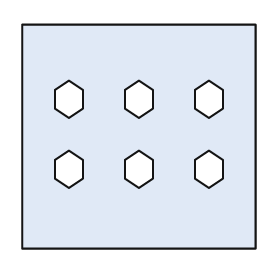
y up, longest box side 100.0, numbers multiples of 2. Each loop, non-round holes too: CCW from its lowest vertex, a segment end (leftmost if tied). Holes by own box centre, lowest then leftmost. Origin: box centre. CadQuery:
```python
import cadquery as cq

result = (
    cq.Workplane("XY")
    .moveTo(-50.0, -48.0)
    .lineTo(50.0, -48.0)
    .lineTo(50.0, 48.0)
    .lineTo(-50.0, 48.0)
    .close()
    .moveTo(-30.0, -22.0)
    .lineTo(-24.0, -18.0)
    .lineTo(-24.0, -10.0)
    .lineTo(-30.0, -6.0)
    .lineTo(-36.0, -10.0)
    .lineTo(-36.0, -18.0)
    .close()
    .moveTo(0.0, -22.0)
    .lineTo(6.0, -18.0)
    .lineTo(6.0, -10.0)
    .lineTo(0.0, -6.0)
    .lineTo(-6.0, -10.0)
    .lineTo(-6.0, -18.0)
    .close()
    .moveTo(30.0, -22.0)
    .lineTo(36.0, -18.0)
    .lineTo(36.0, -10.0)
    .lineTo(30.0, -6.0)
    .lineTo(24.0, -10.0)
    .lineTo(24.0, -18.0)
    .close()
    .moveTo(-30.0, 8.0)
    .lineTo(-24.0, 12.0)
    .lineTo(-24.0, 20.0)
    .lineTo(-30.0, 24.0)
    .lineTo(-36.0, 20.0)
    .lineTo(-36.0, 12.0)
    .close()
    .moveTo(0.0, 8.0)
    .lineTo(6.0, 12.0)
    .lineTo(6.0, 20.0)
    .lineTo(0.0, 24.0)
    .lineTo(-6.0, 20.0)
    .lineTo(-6.0, 12.0)
    .close()
    .moveTo(30.0, 8.0)
    .lineTo(36.0, 12.0)
    .lineTo(36.0, 20.0)
    .lineTo(30.0, 24.0)
    .lineTo(24.0, 20.0)
    .lineTo(24.0, 12.0)
    .close()
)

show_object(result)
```